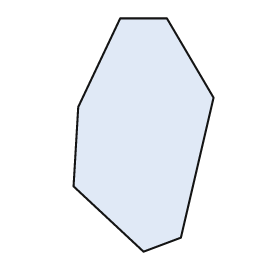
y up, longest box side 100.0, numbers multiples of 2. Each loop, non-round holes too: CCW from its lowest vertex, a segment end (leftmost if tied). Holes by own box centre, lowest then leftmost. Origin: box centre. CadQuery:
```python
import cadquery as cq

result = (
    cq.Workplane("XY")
    .moveTo(0.0, -50.0)
    .lineTo(16.0, -44.0)
    .lineTo(30.0, 16.0)
    .lineTo(10.0, 50.0)
    .lineTo(-10.0, 50.0)
    .lineTo(-28.0, 12.0)
    .lineTo(-30.0, -22.0)
    .close()
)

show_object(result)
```